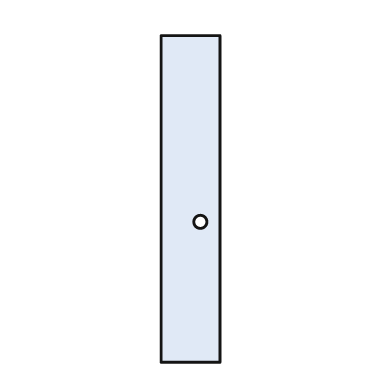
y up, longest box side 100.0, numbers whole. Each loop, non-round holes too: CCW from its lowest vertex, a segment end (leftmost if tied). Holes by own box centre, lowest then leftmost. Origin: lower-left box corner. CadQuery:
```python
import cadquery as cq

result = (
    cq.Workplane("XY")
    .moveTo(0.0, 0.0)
    .lineTo(18.0, 0.0)
    .lineTo(18.0, 100.0)
    .lineTo(0.0, 100.0)
    .close()
    .moveTo(12.0, 43.0)
    .circle(2.0)
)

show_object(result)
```